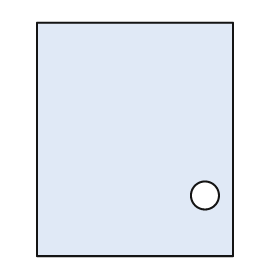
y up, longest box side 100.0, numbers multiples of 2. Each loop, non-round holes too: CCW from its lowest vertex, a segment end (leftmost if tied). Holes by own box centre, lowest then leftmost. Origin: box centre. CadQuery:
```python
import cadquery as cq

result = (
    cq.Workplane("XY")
    .moveTo(-42.0, -50.0)
    .lineTo(42.0, -50.0)
    .lineTo(42.0, 50.0)
    .lineTo(-42.0, 50.0)
    .close()
    .moveTo(30.0, -24.0)
    .circle(6.0)
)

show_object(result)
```